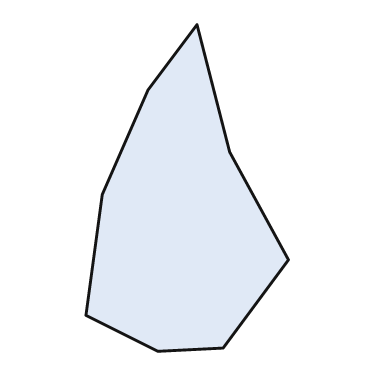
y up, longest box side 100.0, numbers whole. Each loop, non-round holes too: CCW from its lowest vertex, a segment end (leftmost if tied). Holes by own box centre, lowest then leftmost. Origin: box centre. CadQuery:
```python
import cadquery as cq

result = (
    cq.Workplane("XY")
    .moveTo(-9.0, -50.0)
    .lineTo(11.0, -49.0)
    .lineTo(31.0, -22.0)
    .lineTo(13.0, 11.0)
    .lineTo(3.0, 50.0)
    .lineTo(-12.0, 30.0)
    .lineTo(-26.0, -2.0)
    .lineTo(-31.0, -39.0)
    .close()
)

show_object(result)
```